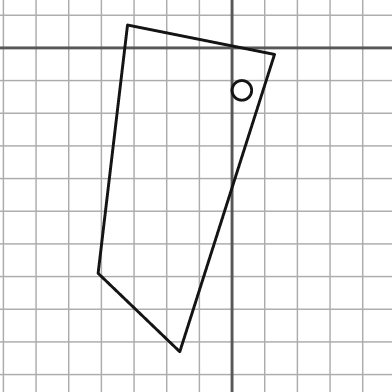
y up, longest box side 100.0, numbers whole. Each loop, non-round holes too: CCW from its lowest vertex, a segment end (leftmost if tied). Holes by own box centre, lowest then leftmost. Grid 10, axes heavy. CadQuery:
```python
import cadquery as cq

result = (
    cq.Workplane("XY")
    .moveTo(-16.0, -93.0)
    .lineTo(13.0, -2.0)
    .lineTo(-32.0, 7.0)
    .lineTo(-41.0, -69.0)
    .close()
    .moveTo(3.0, -13.0)
    .circle(3.0)
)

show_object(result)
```